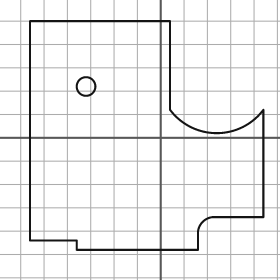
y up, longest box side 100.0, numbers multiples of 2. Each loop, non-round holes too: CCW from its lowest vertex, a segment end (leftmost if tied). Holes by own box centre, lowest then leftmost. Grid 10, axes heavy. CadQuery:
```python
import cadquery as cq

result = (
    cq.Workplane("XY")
    .moveTo(-36.0, -48.0)
    .lineTo(16.0, -48.0)
    .lineTo(16.0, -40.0)
    .threePointArc((18.0, -36.0), (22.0, -34.0))
    .lineTo(44.0, -34.0)
    .lineTo(44.0, 12.0)
    .threePointArc((24.0, 2.0), (4.0, 12.0))
    .lineTo(4.0, 50.0)
    .lineTo(-56.0, 50.0)
    .lineTo(-56.0, -44.0)
    .lineTo(-36.0, -44.0)
    .close()
    .moveTo(-32.0, 22.0)
    .circle(4.0)
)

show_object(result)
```